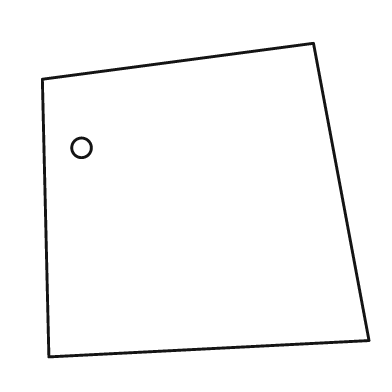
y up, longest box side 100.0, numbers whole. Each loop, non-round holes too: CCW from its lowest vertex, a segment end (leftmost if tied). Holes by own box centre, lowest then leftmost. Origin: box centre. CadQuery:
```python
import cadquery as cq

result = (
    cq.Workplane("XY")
    .moveTo(-48.0, -48.0)
    .lineTo(50.0, -43.0)
    .lineTo(33.0, 48.0)
    .lineTo(-50.0, 37.0)
    .close()
    .moveTo(-38.0, 16.0)
    .circle(3.0)
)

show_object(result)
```